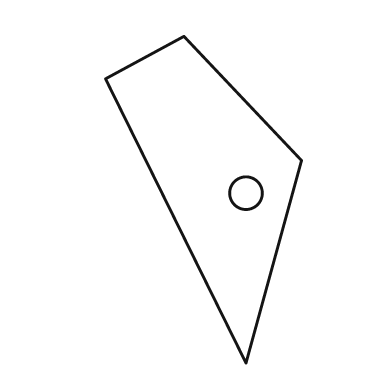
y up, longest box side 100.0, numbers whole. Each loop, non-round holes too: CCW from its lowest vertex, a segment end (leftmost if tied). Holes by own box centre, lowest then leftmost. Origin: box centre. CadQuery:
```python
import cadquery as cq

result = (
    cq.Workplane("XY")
    .moveTo(13.0, -50.0)
    .lineTo(30.0, 12.0)
    .lineTo(-6.0, 50.0)
    .lineTo(-30.0, 37.0)
    .close()
    .moveTo(13.0, 2.0)
    .circle(5.0)
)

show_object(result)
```